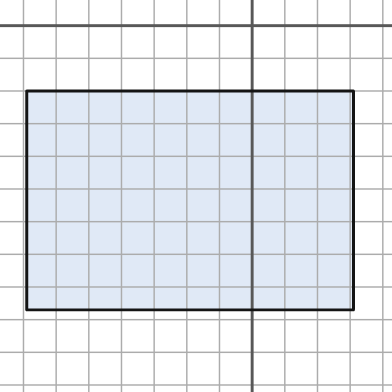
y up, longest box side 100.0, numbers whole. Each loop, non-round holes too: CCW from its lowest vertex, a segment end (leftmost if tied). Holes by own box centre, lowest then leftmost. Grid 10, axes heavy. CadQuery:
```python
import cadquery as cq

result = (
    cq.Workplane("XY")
    .moveTo(-69.0, -87.0)
    .lineTo(31.0, -87.0)
    .lineTo(31.0, -20.0)
    .lineTo(-69.0, -20.0)
    .close()
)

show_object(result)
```